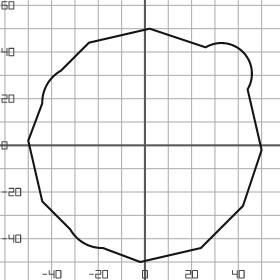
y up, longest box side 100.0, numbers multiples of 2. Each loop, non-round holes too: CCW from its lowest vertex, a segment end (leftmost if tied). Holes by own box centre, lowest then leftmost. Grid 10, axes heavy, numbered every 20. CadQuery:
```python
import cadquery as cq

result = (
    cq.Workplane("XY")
    .moveTo(-2.0, -50.0)
    .lineTo(24.0, -44.0)
    .lineTo(42.0, -26.0)
    .lineTo(50.0, -2.0)
    .lineTo(44.0, 24.0)
    .threePointArc((42.0, 40.0), (26.0, 42.0))
    .lineTo(2.0, 50.0)
    .lineTo(-24.0, 44.0)
    .lineTo(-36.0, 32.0)
    .threePointArc((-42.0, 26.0), (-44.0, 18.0))
    .lineTo(-50.0, 2.0)
    .lineTo(-44.0, -24.0)
    .lineTo(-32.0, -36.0)
    .threePointArc((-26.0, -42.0), (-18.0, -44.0))
    .close()
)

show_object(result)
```